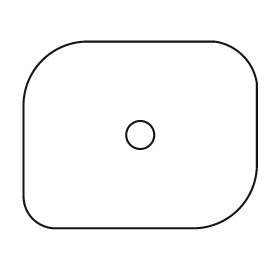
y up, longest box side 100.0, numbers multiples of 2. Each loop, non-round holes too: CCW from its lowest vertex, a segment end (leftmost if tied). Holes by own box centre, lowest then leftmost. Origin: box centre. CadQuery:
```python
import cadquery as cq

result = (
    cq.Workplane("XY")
    .moveTo(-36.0, -40.0)
    .lineTo(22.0, -40.0)
    .threePointArc((42.0, -32.0), (50.0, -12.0))
    .lineTo(50.0, 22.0)
    .threePointArc((44.0, 34.0), (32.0, 40.0))
    .lineTo(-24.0, 40.0)
    .threePointArc((-42.0, 32.0), (-50.0, 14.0))
    .lineTo(-50.0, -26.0)
    .threePointArc((-46.0, -36.0), (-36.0, -40.0))
    .close()
    .moveTo(0.0, 0.0)
    .circle(6.0)
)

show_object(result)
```